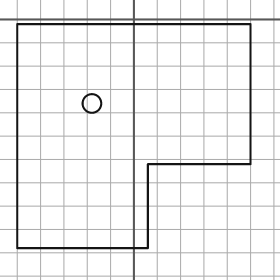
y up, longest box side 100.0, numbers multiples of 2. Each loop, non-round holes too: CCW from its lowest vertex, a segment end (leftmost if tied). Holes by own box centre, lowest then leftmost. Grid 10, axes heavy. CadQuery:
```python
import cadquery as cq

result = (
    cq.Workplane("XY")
    .moveTo(-50.0, -98.0)
    .lineTo(6.0, -98.0)
    .lineTo(6.0, -62.0)
    .lineTo(50.0, -62.0)
    .lineTo(50.0, -2.0)
    .lineTo(-50.0, -2.0)
    .close()
    .moveTo(-18.0, -36.0)
    .circle(4.0)
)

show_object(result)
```